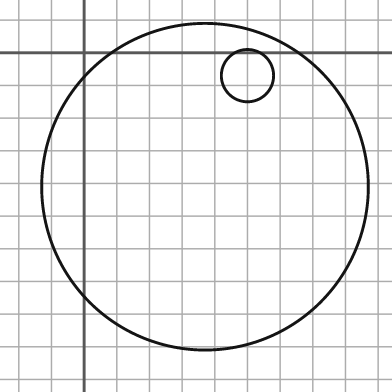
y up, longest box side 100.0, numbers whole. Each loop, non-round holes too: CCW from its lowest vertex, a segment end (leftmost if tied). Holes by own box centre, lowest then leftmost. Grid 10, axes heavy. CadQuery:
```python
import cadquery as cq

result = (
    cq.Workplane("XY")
    .moveTo(37.0, -41.0)
    .circle(50.0)
    .moveTo(50.0, -7.0)
    .circle(8.0)
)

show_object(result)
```